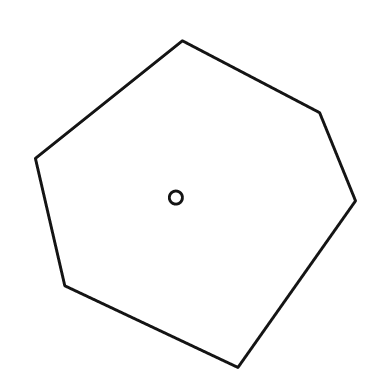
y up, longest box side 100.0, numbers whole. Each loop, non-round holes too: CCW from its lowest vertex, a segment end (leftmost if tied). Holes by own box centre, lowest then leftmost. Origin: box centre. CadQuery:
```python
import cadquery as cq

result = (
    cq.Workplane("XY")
    .moveTo(13.0, -50.0)
    .lineTo(49.0, 1.0)
    .lineTo(38.0, 28.0)
    .lineTo(-4.0, 50.0)
    .lineTo(-49.0, 14.0)
    .lineTo(-40.0, -25.0)
    .close()
    .moveTo(-6.0, 2.0)
    .circle(2.0)
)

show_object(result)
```